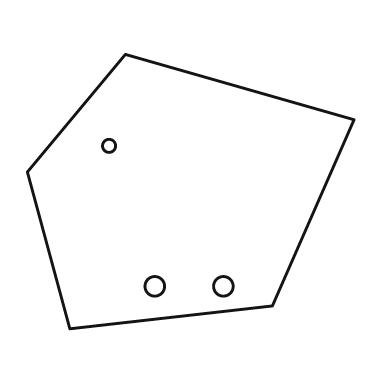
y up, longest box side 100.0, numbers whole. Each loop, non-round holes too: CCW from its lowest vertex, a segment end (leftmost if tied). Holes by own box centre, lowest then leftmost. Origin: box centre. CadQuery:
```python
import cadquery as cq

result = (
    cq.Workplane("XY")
    .moveTo(-37.0, -42.0)
    .lineTo(25.0, -35.0)
    .lineTo(50.0, 22.0)
    .lineTo(-20.0, 42.0)
    .lineTo(-50.0, 6.0)
    .close()
    .moveTo(-11.0, -29.0)
    .circle(3.0)
    .moveTo(10.0, -29.0)
    .circle(3.0)
    .moveTo(-25.0, 14.0)
    .circle(2.0)
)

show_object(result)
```